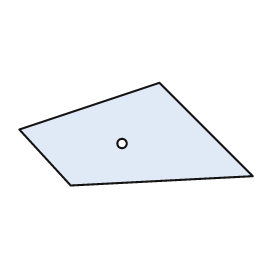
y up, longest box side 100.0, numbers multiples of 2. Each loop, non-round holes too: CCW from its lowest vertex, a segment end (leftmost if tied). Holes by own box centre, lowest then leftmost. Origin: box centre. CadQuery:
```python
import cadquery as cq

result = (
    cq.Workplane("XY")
    .moveTo(-28.0, -22.0)
    .lineTo(50.0, -18.0)
    .lineTo(10.0, 22.0)
    .lineTo(-50.0, 2.0)
    .close()
    .moveTo(-6.0, -4.0)
    .circle(2.0)
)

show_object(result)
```